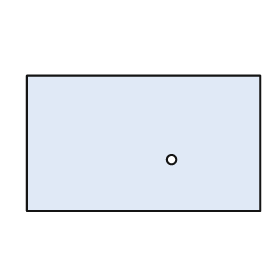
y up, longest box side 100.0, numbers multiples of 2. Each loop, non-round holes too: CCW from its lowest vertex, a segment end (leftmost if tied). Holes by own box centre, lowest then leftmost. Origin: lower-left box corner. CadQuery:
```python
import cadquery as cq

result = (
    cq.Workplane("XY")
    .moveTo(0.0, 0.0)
    .lineTo(100.0, 0.0)
    .lineTo(100.0, 58.0)
    .lineTo(0.0, 58.0)
    .close()
    .moveTo(62.0, 22.0)
    .circle(2.0)
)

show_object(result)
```